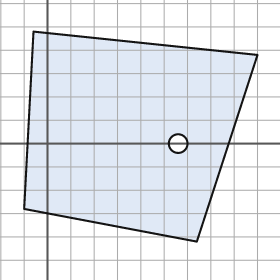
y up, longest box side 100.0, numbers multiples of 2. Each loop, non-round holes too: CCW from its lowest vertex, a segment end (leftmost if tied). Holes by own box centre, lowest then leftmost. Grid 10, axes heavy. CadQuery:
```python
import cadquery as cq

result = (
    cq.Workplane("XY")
    .moveTo(64.0, -42.0)
    .lineTo(90.0, 38.0)
    .lineTo(-6.0, 48.0)
    .lineTo(-10.0, -28.0)
    .close()
    .moveTo(56.0, 0.0)
    .circle(4.0)
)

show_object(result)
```